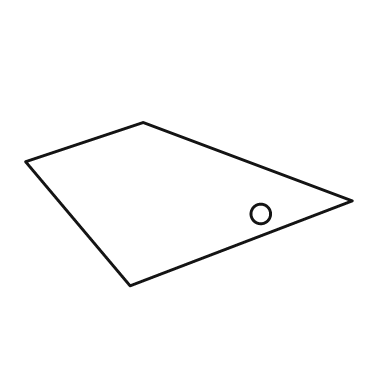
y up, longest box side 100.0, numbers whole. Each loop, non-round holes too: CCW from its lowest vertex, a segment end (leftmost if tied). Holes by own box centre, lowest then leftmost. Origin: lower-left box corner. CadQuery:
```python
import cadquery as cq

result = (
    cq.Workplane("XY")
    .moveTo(32.0, 0.0)
    .lineTo(100.0, 26.0)
    .lineTo(36.0, 50.0)
    .lineTo(0.0, 38.0)
    .close()
    .moveTo(72.0, 22.0)
    .circle(3.0)
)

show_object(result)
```